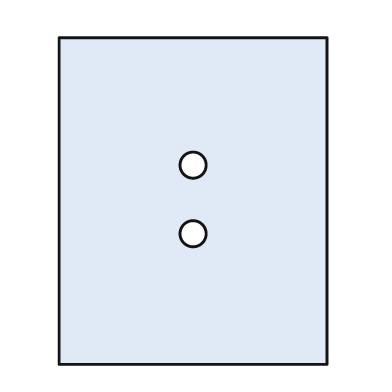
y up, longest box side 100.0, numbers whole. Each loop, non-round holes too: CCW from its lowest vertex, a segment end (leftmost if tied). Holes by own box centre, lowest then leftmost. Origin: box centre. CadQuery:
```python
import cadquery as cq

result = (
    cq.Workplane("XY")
    .moveTo(-41.0, -50.0)
    .lineTo(41.0, -50.0)
    .lineTo(41.0, 50.0)
    .lineTo(-41.0, 50.0)
    .close()
    .moveTo(0.0, -10.0)
    .circle(4.0)
    .moveTo(0.0, 11.0)
    .circle(4.0)
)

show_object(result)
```